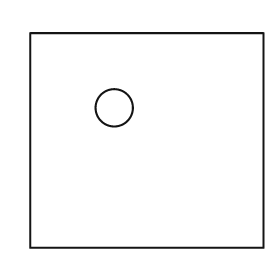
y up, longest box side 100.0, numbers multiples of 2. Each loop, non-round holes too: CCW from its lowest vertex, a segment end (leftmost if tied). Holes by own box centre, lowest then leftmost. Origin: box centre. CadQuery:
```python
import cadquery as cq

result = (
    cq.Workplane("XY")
    .moveTo(-50.0, -46.0)
    .lineTo(50.0, -46.0)
    .lineTo(50.0, 46.0)
    .lineTo(-50.0, 46.0)
    .close()
    .moveTo(-14.0, 14.0)
    .circle(8.0)
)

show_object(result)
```